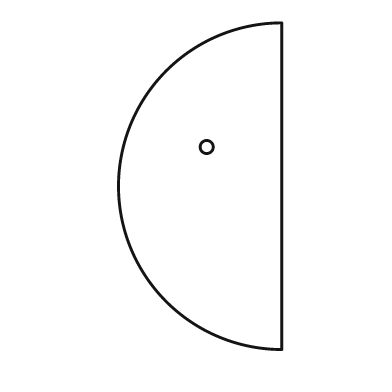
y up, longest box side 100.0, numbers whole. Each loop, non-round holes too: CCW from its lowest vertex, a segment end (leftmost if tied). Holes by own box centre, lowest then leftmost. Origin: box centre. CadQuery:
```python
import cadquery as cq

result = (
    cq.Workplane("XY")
    .moveTo(25.0, -50.0)
    .lineTo(25.0, 50.0)
    .threePointArc((-25.0, 0.0), (25.0, -50.0))
    .close()
    .moveTo(2.0, 12.0)
    .circle(2.0)
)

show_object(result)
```